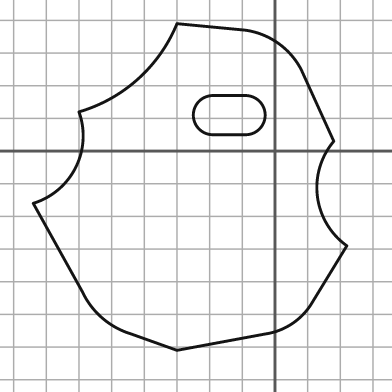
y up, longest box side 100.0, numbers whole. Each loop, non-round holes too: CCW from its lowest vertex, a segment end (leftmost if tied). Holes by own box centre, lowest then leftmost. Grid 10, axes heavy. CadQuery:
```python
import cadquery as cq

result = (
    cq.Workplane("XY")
    .moveTo(-30.0, -61.0)
    .lineTo(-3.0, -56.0)
    .threePointArc((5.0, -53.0), (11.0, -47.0))
    .lineTo(22.0, -29.0)
    .threePointArc((13.0, -14.0), (18.0, 3.0))
    .lineTo(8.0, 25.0)
    .threePointArc((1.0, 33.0), (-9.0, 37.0))
    .lineTo(-30.0, 39.0)
    .threePointArc((-42.0, 22.0), (-60.0, 12.0))
    .threePointArc((-61.0, -5.0), (-74.0, -16.0))
    .lineTo(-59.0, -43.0)
    .threePointArc((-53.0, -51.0), (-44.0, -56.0))
    .close()
    .moveTo(-19.0, 5.0)
    .lineTo(-9.0, 5.0)
    .threePointArc((-3.0, 11.0), (-9.0, 17.0))
    .lineTo(-19.0, 17.0)
    .threePointArc((-25.0, 11.0), (-19.0, 5.0))
    .close()
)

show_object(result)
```